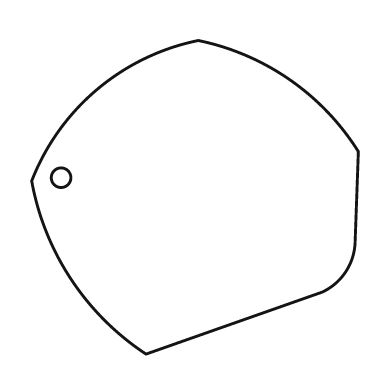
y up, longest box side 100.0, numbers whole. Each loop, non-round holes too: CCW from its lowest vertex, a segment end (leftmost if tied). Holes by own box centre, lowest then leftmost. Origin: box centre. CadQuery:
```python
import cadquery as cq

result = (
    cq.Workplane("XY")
    .moveTo(-15.0, -48.0)
    .lineTo(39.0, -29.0)
    .threePointArc((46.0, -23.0), (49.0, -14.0))
    .lineTo(50.0, 14.0)
    .threePointArc((29.0, 36.0), (1.0, 48.0))
    .threePointArc((-30.0, 33.0), (-50.0, 5.0))
    .threePointArc((-38.0, -25.0), (-15.0, -48.0))
    .close()
    .moveTo(-41.0, 6.0)
    .circle(3.0)
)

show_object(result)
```